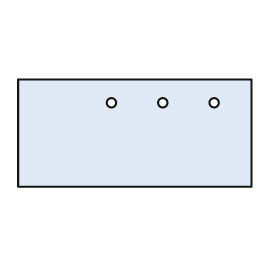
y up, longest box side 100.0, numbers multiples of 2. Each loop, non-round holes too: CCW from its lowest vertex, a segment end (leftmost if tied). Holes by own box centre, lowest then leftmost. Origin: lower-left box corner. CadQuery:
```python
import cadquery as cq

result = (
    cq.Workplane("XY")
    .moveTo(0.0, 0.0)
    .lineTo(100.0, 0.0)
    .lineTo(100.0, 46.0)
    .lineTo(0.0, 46.0)
    .close()
    .moveTo(40.0, 36.0)
    .circle(2.0)
    .moveTo(62.0, 36.0)
    .circle(2.0)
    .moveTo(84.0, 36.0)
    .circle(2.0)
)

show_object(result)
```